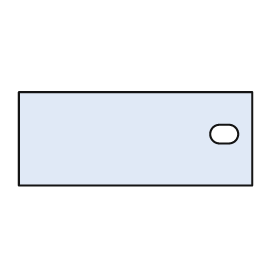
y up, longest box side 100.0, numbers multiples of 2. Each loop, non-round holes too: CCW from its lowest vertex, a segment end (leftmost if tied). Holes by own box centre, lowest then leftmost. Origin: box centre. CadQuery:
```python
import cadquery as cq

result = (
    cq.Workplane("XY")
    .moveTo(-50.0, -20.0)
    .lineTo(50.0, -20.0)
    .lineTo(50.0, 20.0)
    .lineTo(-50.0, 20.0)
    .close()
    .moveTo(36.0, -2.0)
    .lineTo(40.0, -2.0)
    .threePointArc((44.0, 2.0), (40.0, 6.0))
    .lineTo(36.0, 6.0)
    .threePointArc((32.0, 2.0), (36.0, -2.0))
    .close()
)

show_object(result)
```